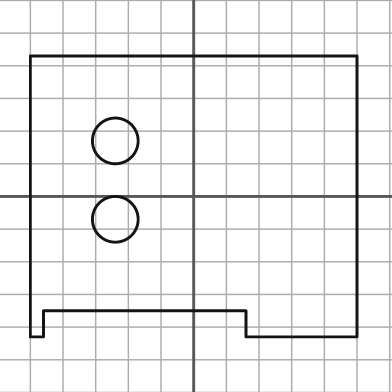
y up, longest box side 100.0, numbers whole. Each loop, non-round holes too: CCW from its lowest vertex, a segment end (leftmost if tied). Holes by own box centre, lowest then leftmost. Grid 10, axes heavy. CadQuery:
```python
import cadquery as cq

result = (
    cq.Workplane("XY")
    .moveTo(-50.0, -43.0)
    .lineTo(-46.0, -43.0)
    .lineTo(-46.0, -35.0)
    .lineTo(16.0, -35.0)
    .lineTo(16.0, -43.0)
    .lineTo(50.0, -43.0)
    .lineTo(50.0, 43.0)
    .lineTo(-50.0, 43.0)
    .close()
    .moveTo(-24.0, -7.0)
    .circle(7.0)
    .moveTo(-24.0, 17.0)
    .circle(7.0)
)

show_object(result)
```